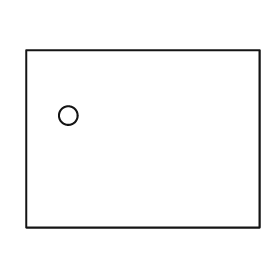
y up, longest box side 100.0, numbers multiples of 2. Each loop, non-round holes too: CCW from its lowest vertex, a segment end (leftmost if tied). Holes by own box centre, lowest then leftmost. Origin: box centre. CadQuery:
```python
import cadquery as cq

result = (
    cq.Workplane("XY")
    .moveTo(-50.0, -38.0)
    .lineTo(50.0, -38.0)
    .lineTo(50.0, 38.0)
    .lineTo(-50.0, 38.0)
    .close()
    .moveTo(-32.0, 10.0)
    .circle(4.0)
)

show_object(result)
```